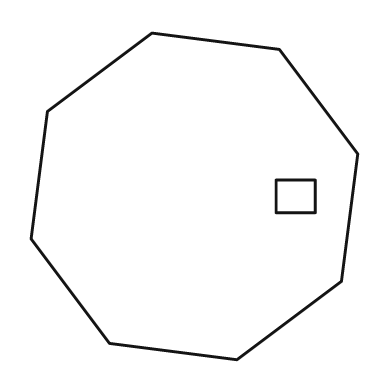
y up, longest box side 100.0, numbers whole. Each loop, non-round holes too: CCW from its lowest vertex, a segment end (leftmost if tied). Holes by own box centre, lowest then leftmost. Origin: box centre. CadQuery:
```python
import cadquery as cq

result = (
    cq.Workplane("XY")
    .moveTo(13.0, -50.0)
    .lineTo(45.0, -26.0)
    .lineTo(50.0, 13.0)
    .lineTo(26.0, 45.0)
    .lineTo(-13.0, 50.0)
    .lineTo(-45.0, 26.0)
    .lineTo(-50.0, -13.0)
    .lineTo(-26.0, -45.0)
    .close()
    .moveTo(25.0, -5.0)
    .lineTo(37.0, -5.0)
    .lineTo(37.0, 5.0)
    .lineTo(25.0, 5.0)
    .close()
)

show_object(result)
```